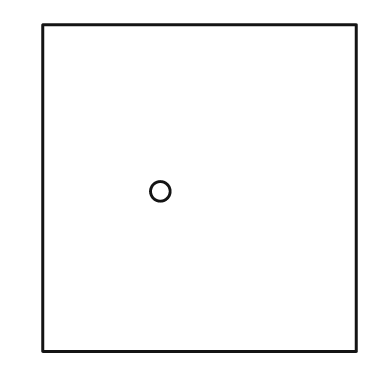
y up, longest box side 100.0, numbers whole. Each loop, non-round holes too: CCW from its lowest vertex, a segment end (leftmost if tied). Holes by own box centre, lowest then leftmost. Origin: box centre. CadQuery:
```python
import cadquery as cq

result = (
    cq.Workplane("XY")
    .moveTo(-48.0, -50.0)
    .lineTo(48.0, -50.0)
    .lineTo(48.0, 50.0)
    .lineTo(-48.0, 50.0)
    .close()
    .moveTo(-12.0, -1.0)
    .circle(3.0)
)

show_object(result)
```